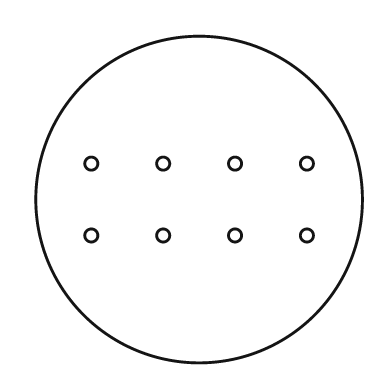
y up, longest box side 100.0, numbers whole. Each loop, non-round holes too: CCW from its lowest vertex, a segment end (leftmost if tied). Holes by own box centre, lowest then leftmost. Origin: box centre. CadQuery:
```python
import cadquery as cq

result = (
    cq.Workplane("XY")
    .moveTo(0.0, 0.0)
    .circle(50.0)
    .moveTo(-33.0, -11.0)
    .circle(2.0)
    .moveTo(-11.0, -11.0)
    .circle(2.0)
    .moveTo(11.0, -11.0)
    .circle(2.0)
    .moveTo(33.0, -11.0)
    .circle(2.0)
    .moveTo(-33.0, 11.0)
    .circle(2.0)
    .moveTo(-11.0, 11.0)
    .circle(2.0)
    .moveTo(11.0, 11.0)
    .circle(2.0)
    .moveTo(33.0, 11.0)
    .circle(2.0)
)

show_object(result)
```